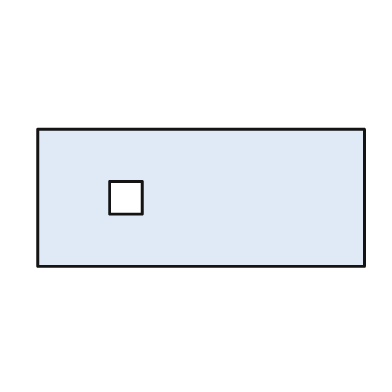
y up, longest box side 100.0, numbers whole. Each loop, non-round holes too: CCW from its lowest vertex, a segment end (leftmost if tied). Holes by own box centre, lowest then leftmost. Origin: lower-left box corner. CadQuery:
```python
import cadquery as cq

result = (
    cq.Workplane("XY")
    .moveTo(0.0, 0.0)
    .lineTo(100.0, 0.0)
    .lineTo(100.0, 42.0)
    .lineTo(0.0, 42.0)
    .close()
    .moveTo(22.0, 16.0)
    .lineTo(32.0, 16.0)
    .lineTo(32.0, 26.0)
    .lineTo(22.0, 26.0)
    .close()
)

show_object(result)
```